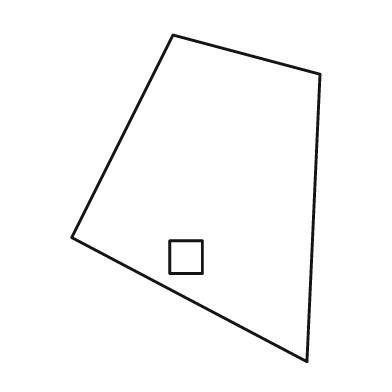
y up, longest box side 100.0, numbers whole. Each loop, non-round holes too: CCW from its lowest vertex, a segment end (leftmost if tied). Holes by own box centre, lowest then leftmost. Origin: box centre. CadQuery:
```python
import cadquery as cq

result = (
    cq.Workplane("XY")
    .moveTo(34.0, -50.0)
    .lineTo(38.0, 38.0)
    .lineTo(-7.0, 50.0)
    .lineTo(-38.0, -12.0)
    .close()
    .moveTo(-8.0, -23.0)
    .lineTo(2.0, -23.0)
    .lineTo(2.0, -13.0)
    .lineTo(-8.0, -13.0)
    .close()
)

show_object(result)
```